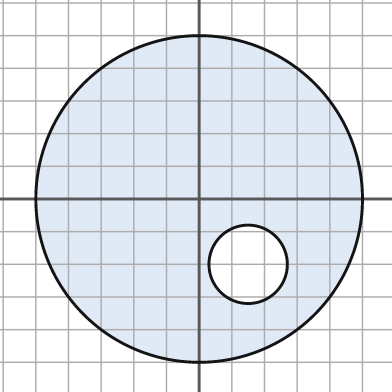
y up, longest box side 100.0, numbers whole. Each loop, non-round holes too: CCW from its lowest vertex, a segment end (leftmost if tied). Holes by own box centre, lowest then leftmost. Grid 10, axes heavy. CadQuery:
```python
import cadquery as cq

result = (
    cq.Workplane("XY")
    .moveTo(0.0, 0.0)
    .circle(50.0)
    .moveTo(15.0, -20.0)
    .circle(12.0)
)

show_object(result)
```